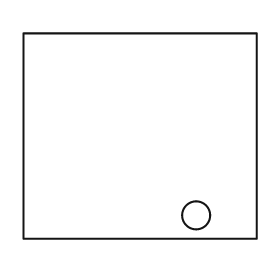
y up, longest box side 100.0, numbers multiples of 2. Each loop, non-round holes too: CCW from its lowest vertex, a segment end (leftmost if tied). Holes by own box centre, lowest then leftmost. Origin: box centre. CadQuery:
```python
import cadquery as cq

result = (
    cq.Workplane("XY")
    .moveTo(-50.0, -44.0)
    .lineTo(50.0, -44.0)
    .lineTo(50.0, 44.0)
    .lineTo(-50.0, 44.0)
    .close()
    .moveTo(24.0, -34.0)
    .circle(6.0)
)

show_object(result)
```